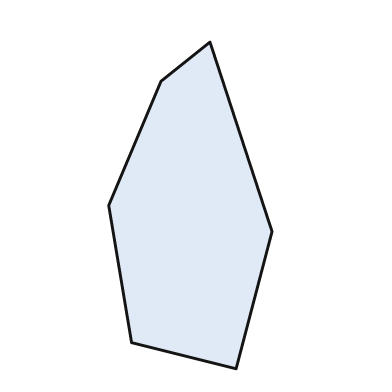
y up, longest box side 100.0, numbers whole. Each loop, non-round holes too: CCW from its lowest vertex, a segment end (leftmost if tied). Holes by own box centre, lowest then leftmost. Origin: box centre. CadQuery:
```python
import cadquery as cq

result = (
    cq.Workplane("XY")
    .moveTo(14.0, -50.0)
    .lineTo(25.0, -8.0)
    .lineTo(6.0, 50.0)
    .lineTo(-9.0, 38.0)
    .lineTo(-25.0, 0.0)
    .lineTo(-18.0, -42.0)
    .close()
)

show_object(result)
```